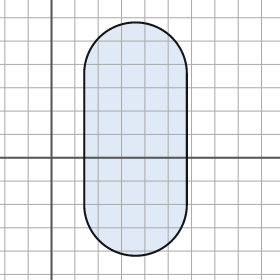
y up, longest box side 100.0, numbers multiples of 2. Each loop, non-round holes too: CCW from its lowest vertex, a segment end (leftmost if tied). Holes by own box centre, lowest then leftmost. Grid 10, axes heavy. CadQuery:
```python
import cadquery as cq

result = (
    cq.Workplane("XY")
    .moveTo(14.0, -20.0)
    .threePointArc((36.0, -42.0), (58.0, -20.0))
    .lineTo(58.0, 36.0)
    .threePointArc((36.0, 58.0), (14.0, 36.0))
    .close()
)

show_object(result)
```